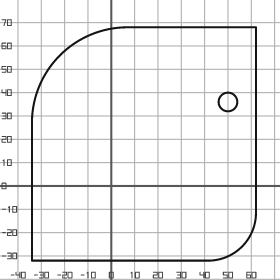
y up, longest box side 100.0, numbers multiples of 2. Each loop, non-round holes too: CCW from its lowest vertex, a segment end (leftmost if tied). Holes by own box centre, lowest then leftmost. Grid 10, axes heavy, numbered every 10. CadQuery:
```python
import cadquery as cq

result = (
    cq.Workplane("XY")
    .moveTo(-34.0, -32.0)
    .lineTo(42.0, -32.0)
    .threePointArc((56.0, -26.0), (62.0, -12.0))
    .lineTo(62.0, 68.0)
    .lineTo(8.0, 68.0)
    .threePointArc((-22.0, 56.0), (-34.0, 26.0))
    .close()
    .moveTo(50.0, 36.0)
    .circle(4.0)
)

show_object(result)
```